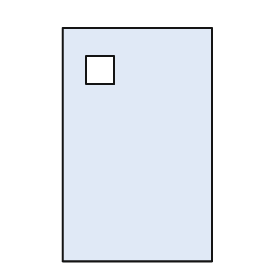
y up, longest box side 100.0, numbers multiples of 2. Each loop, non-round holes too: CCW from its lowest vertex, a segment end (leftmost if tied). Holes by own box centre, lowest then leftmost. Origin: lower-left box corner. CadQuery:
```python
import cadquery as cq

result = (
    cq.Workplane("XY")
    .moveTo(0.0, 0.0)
    .lineTo(64.0, 0.0)
    .lineTo(64.0, 100.0)
    .lineTo(0.0, 100.0)
    .close()
    .moveTo(10.0, 76.0)
    .lineTo(22.0, 76.0)
    .lineTo(22.0, 88.0)
    .lineTo(10.0, 88.0)
    .close()
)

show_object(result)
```